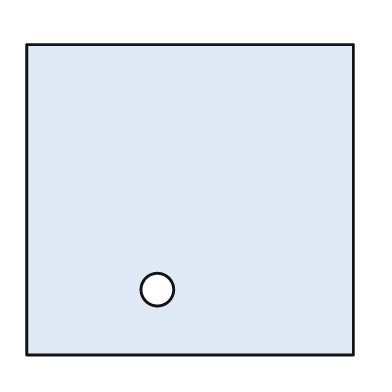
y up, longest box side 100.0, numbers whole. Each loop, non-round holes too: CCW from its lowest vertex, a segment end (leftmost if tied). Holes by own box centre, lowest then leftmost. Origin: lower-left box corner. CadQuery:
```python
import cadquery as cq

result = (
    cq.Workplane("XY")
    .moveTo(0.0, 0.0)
    .lineTo(100.0, 0.0)
    .lineTo(100.0, 95.0)
    .lineTo(0.0, 95.0)
    .close()
    .moveTo(40.0, 20.0)
    .circle(5.0)
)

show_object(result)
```